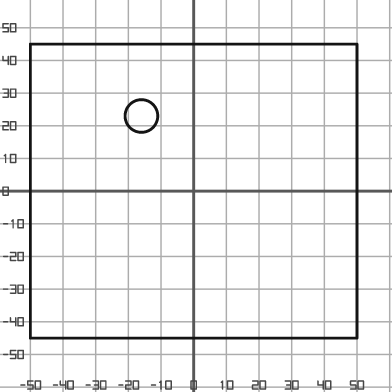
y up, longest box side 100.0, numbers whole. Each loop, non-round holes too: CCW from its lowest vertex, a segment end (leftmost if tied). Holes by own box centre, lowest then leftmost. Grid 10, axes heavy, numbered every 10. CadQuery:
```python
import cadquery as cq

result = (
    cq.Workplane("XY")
    .moveTo(-50.0, -45.0)
    .lineTo(50.0, -45.0)
    .lineTo(50.0, 45.0)
    .lineTo(-50.0, 45.0)
    .close()
    .moveTo(-16.0, 23.0)
    .circle(5.0)
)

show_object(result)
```